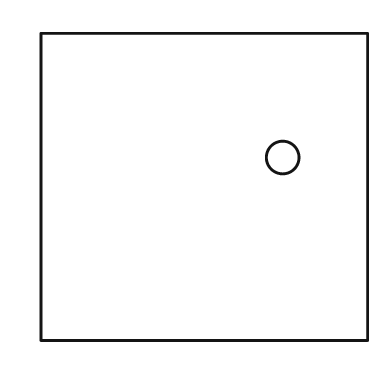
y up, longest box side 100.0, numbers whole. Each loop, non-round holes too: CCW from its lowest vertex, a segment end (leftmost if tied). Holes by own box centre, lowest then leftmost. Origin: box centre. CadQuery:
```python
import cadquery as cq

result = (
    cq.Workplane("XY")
    .moveTo(-50.0, -47.0)
    .lineTo(50.0, -47.0)
    .lineTo(50.0, 47.0)
    .lineTo(-50.0, 47.0)
    .close()
    .moveTo(24.0, 9.0)
    .circle(5.0)
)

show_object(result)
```